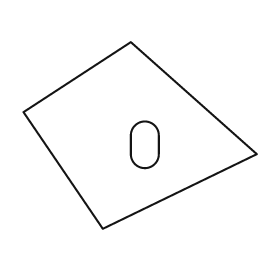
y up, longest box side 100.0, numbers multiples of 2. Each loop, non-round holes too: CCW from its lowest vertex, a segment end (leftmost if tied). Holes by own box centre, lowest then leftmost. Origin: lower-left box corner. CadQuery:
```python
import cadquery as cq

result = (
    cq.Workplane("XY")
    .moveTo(34.0, 0.0)
    .lineTo(100.0, 32.0)
    .lineTo(46.0, 80.0)
    .lineTo(0.0, 50.0)
    .close()
    .moveTo(46.0, 32.0)
    .threePointArc((52.0, 26.0), (58.0, 32.0))
    .lineTo(58.0, 40.0)
    .threePointArc((52.0, 46.0), (46.0, 40.0))
    .close()
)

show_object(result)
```